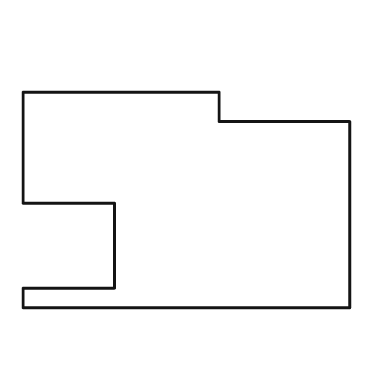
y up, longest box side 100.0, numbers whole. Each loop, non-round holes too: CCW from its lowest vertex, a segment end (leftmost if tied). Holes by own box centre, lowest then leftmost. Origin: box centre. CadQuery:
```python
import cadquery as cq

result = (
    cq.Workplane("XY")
    .moveTo(-50.0, -33.0)
    .lineTo(50.0, -33.0)
    .lineTo(50.0, 24.0)
    .lineTo(10.0, 24.0)
    .lineTo(10.0, 33.0)
    .lineTo(-50.0, 33.0)
    .lineTo(-50.0, -1.0)
    .lineTo(-22.0, -1.0)
    .lineTo(-22.0, -27.0)
    .lineTo(-50.0, -27.0)
    .close()
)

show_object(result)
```